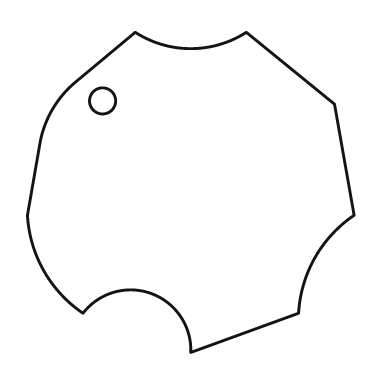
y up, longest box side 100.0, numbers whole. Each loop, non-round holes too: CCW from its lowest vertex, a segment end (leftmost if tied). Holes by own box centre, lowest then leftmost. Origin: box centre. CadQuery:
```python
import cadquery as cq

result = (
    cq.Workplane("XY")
    .moveTo(0.0, -49.0)
    .lineTo(33.0, -37.0)
    .threePointArc((38.0, -20.0), (50.0, -7.0))
    .lineTo(44.0, 27.0)
    .lineTo(17.0, 49.0)
    .threePointArc((0.0, 44.0), (-17.0, 49.0))
    .lineTo(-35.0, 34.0)
    .threePointArc((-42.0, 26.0), (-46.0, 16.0))
    .lineTo(-50.0, -7.0)
    .threePointArc((-45.0, -24.0), (-33.0, -37.0))
    .threePointArc((-12.0, -31.0), (0.0, -49.0))
    .close()
    .moveTo(-27.0, 28.0)
    .circle(4.0)
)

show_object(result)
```